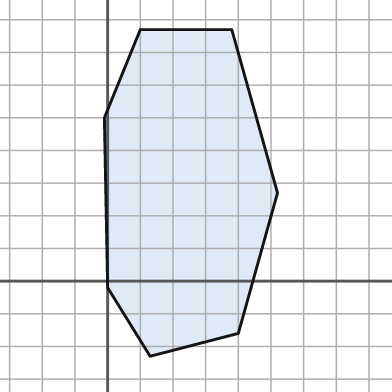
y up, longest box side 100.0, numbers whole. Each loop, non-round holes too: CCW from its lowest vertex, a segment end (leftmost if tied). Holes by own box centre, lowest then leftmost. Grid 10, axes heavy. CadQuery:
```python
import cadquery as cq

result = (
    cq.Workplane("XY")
    .moveTo(13.0, -23.0)
    .lineTo(40.0, -16.0)
    .lineTo(52.0, 27.0)
    .lineTo(38.0, 77.0)
    .lineTo(10.0, 77.0)
    .lineTo(-1.0, 50.0)
    .lineTo(0.0, -2.0)
    .close()
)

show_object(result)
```